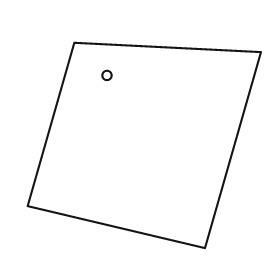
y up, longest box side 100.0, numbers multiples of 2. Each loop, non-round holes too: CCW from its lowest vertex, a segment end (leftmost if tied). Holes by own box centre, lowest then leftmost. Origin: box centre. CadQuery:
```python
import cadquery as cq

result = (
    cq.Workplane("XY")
    .moveTo(26.0, -44.0)
    .lineTo(50.0, 40.0)
    .lineTo(-30.0, 44.0)
    .lineTo(-50.0, -26.0)
    .close()
    .moveTo(-16.0, 30.0)
    .circle(2.0)
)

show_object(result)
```